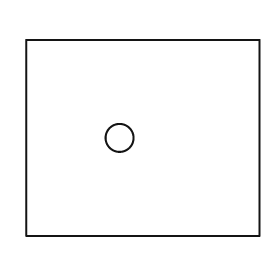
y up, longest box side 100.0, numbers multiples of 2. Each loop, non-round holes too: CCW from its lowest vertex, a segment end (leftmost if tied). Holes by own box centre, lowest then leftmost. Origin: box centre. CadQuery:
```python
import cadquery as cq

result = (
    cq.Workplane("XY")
    .moveTo(-50.0, -42.0)
    .lineTo(50.0, -42.0)
    .lineTo(50.0, 42.0)
    .lineTo(-50.0, 42.0)
    .close()
    .moveTo(-10.0, 0.0)
    .circle(6.0)
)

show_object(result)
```